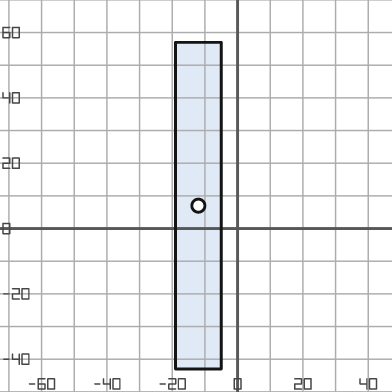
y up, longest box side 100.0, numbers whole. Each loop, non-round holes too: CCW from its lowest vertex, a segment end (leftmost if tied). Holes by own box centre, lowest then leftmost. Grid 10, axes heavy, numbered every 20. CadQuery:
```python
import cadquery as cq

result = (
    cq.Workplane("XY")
    .moveTo(-19.0, -43.0)
    .lineTo(-5.0, -43.0)
    .lineTo(-5.0, 57.0)
    .lineTo(-19.0, 57.0)
    .close()
    .moveTo(-12.0, 7.0)
    .circle(2.0)
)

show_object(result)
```